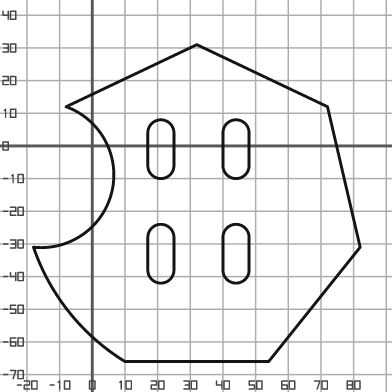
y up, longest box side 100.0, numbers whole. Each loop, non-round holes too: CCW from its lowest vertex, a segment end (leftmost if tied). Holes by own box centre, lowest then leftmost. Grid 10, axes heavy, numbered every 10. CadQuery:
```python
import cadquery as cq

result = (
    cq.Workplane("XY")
    .moveTo(10.0, -66.0)
    .lineTo(54.0, -66.0)
    .lineTo(82.0, -31.0)
    .lineTo(72.0, 12.0)
    .lineTo(32.0, 31.0)
    .lineTo(-8.0, 12.0)
    .threePointArc((6.0, -14.0), (-18.0, -31.0))
    .threePointArc((-7.0, -51.0), (10.0, -66.0))
    .close()
    .moveTo(17.0, -38.0)
    .threePointArc((21.0, -42.0), (25.0, -38.0))
    .lineTo(25.0, -28.0)
    .threePointArc((21.0, -24.0), (17.0, -28.0))
    .close()
    .moveTo(40.0, -38.0)
    .threePointArc((44.0, -42.0), (48.0, -38.0))
    .lineTo(48.0, -28.0)
    .threePointArc((44.0, -24.0), (40.0, -28.0))
    .close()
    .moveTo(17.0, -6.0)
    .threePointArc((21.0, -10.0), (25.0, -6.0))
    .lineTo(25.0, 4.0)
    .threePointArc((21.0, 8.0), (17.0, 4.0))
    .close()
    .moveTo(40.0, -6.0)
    .threePointArc((44.0, -10.0), (48.0, -6.0))
    .lineTo(48.0, 4.0)
    .threePointArc((44.0, 8.0), (40.0, 4.0))
    .close()
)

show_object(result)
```